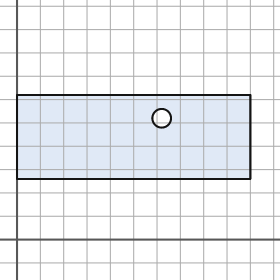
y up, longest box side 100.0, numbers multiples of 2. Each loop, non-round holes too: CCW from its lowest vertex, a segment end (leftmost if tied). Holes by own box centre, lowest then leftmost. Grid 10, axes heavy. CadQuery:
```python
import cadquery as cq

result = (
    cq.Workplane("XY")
    .moveTo(0.0, 26.0)
    .lineTo(100.0, 26.0)
    .lineTo(100.0, 62.0)
    .lineTo(0.0, 62.0)
    .close()
    .moveTo(62.0, 52.0)
    .circle(4.0)
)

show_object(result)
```